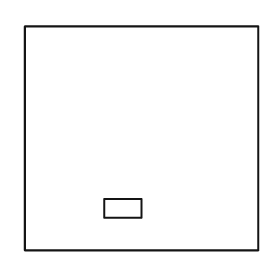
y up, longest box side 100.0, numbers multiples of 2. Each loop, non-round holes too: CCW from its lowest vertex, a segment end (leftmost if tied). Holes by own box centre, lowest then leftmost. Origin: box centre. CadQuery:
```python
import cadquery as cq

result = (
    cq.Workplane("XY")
    .moveTo(-50.0, -48.0)
    .lineTo(50.0, -48.0)
    .lineTo(50.0, 48.0)
    .lineTo(-50.0, 48.0)
    .close()
    .moveTo(-16.0, -34.0)
    .lineTo(0.0, -34.0)
    .lineTo(0.0, -26.0)
    .lineTo(-16.0, -26.0)
    .close()
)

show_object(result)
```